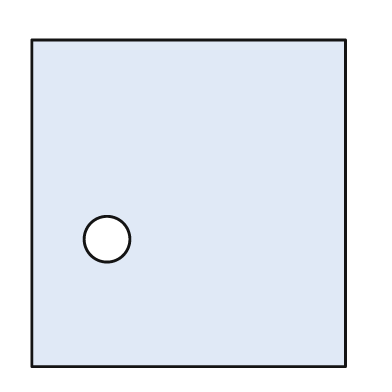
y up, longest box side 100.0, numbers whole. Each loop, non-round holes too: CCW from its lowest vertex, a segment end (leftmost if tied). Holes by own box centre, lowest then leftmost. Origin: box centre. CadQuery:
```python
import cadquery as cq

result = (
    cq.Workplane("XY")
    .moveTo(-48.0, -50.0)
    .lineTo(48.0, -50.0)
    .lineTo(48.0, 50.0)
    .lineTo(-48.0, 50.0)
    .close()
    .moveTo(-25.0, -11.0)
    .circle(7.0)
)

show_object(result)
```